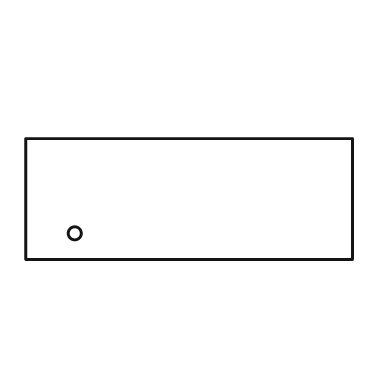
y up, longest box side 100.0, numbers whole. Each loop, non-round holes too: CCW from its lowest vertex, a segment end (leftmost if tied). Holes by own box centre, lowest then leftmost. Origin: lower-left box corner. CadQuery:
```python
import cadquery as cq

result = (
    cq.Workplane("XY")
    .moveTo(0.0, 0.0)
    .lineTo(100.0, 0.0)
    .lineTo(100.0, 37.0)
    .lineTo(0.0, 37.0)
    .close()
    .moveTo(15.0, 8.0)
    .circle(2.0)
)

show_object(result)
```